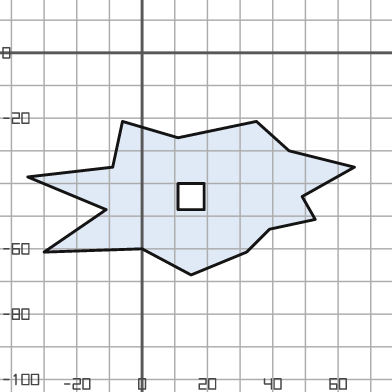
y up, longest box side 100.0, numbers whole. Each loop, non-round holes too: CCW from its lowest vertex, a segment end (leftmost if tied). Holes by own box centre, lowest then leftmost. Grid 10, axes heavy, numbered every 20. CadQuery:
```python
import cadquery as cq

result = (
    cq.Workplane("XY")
    .moveTo(15.0, -68.0)
    .lineTo(32.0, -61.0)
    .lineTo(39.0, -54.0)
    .lineTo(53.0, -51.0)
    .lineTo(49.0, -44.0)
    .lineTo(65.0, -35.0)
    .lineTo(45.0, -30.0)
    .lineTo(35.0, -21.0)
    .lineTo(11.0, -26.0)
    .lineTo(-6.0, -21.0)
    .lineTo(-9.0, -35.0)
    .lineTo(-35.0, -38.0)
    .lineTo(-11.0, -48.0)
    .lineTo(-30.0, -61.0)
    .lineTo(0.0, -60.0)
    .close()
    .moveTo(11.0, -48.0)
    .lineTo(19.0, -48.0)
    .lineTo(19.0, -40.0)
    .lineTo(11.0, -40.0)
    .close()
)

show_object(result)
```